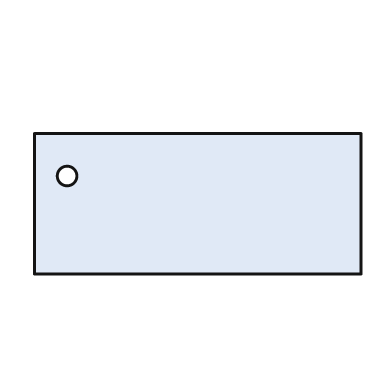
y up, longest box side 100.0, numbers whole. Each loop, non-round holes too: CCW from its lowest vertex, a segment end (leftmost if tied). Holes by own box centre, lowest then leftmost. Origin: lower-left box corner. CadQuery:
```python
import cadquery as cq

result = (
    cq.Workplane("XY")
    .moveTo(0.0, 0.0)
    .lineTo(100.0, 0.0)
    .lineTo(100.0, 43.0)
    .lineTo(0.0, 43.0)
    .close()
    .moveTo(10.0, 30.0)
    .circle(3.0)
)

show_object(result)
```